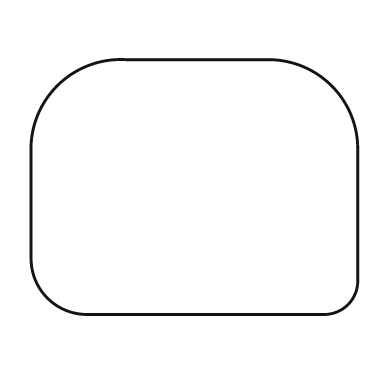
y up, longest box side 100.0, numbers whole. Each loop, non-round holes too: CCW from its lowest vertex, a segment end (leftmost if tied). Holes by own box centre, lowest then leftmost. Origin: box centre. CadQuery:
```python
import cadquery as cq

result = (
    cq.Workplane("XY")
    .moveTo(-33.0, -39.0)
    .lineTo(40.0, -39.0)
    .threePointArc((47.0, -36.0), (50.0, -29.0))
    .lineTo(50.0, 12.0)
    .threePointArc((42.0, 31.0), (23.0, 39.0))
    .lineTo(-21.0, 39.0)
    .threePointArc((-42.0, 31.0), (-50.0, 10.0))
    .lineTo(-50.0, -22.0)
    .threePointArc((-45.0, -34.0), (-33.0, -39.0))
    .close()
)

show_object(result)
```